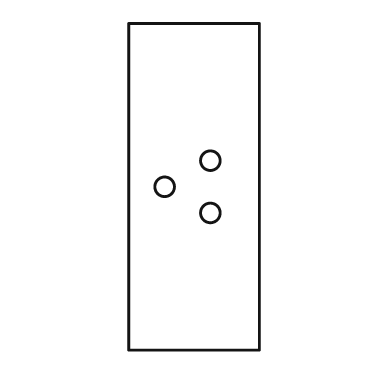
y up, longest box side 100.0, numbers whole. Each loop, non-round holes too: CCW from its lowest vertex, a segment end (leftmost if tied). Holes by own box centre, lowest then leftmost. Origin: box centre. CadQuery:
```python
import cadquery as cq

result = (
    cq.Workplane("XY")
    .moveTo(-20.0, -50.0)
    .lineTo(20.0, -50.0)
    .lineTo(20.0, 50.0)
    .lineTo(-20.0, 50.0)
    .close()
    .moveTo(5.0, -8.0)
    .circle(3.0)
    .moveTo(-9.0, 0.0)
    .circle(3.0)
    .moveTo(5.0, 8.0)
    .circle(3.0)
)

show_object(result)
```